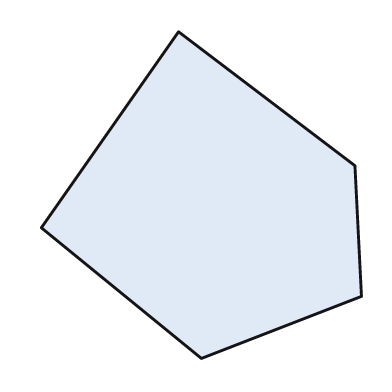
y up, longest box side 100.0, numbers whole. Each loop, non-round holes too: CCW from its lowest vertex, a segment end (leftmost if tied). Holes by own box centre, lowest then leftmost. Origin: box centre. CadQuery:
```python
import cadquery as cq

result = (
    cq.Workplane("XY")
    .moveTo(0.0, -50.0)
    .lineTo(49.0, -31.0)
    .lineTo(47.0, 9.0)
    .lineTo(-7.0, 50.0)
    .lineTo(-49.0, -10.0)
    .close()
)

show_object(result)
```